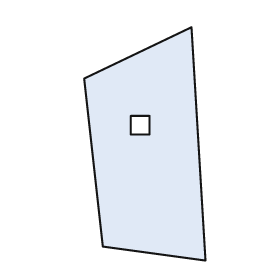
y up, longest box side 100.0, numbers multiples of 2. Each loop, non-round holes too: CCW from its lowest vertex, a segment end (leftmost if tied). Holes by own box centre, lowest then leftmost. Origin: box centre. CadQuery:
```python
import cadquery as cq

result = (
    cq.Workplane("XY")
    .moveTo(26.0, -50.0)
    .lineTo(20.0, 50.0)
    .lineTo(-26.0, 28.0)
    .lineTo(-18.0, -44.0)
    .close()
    .moveTo(-6.0, 4.0)
    .lineTo(2.0, 4.0)
    .lineTo(2.0, 12.0)
    .lineTo(-6.0, 12.0)
    .close()
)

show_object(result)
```